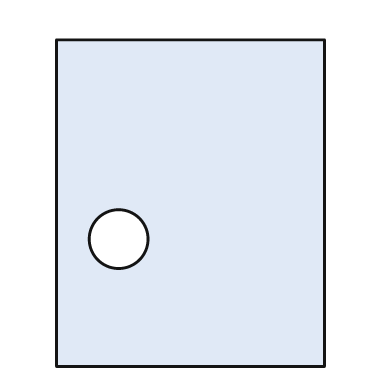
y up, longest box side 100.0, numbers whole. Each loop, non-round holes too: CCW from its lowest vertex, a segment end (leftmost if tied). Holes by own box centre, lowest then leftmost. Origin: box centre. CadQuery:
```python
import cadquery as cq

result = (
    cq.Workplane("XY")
    .moveTo(-41.0, -50.0)
    .lineTo(41.0, -50.0)
    .lineTo(41.0, 50.0)
    .lineTo(-41.0, 50.0)
    .close()
    .moveTo(-22.0, -11.0)
    .circle(9.0)
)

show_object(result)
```